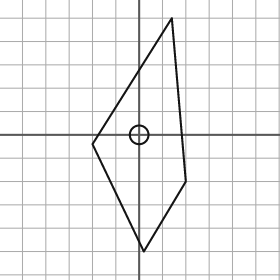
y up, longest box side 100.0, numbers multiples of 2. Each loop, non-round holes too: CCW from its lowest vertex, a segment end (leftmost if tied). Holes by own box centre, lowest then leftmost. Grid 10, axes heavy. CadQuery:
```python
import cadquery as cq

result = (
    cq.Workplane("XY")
    .moveTo(2.0, -50.0)
    .lineTo(20.0, -20.0)
    .lineTo(14.0, 50.0)
    .lineTo(-20.0, -4.0)
    .close()
    .moveTo(0.0, 0.0)
    .circle(4.0)
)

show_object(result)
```